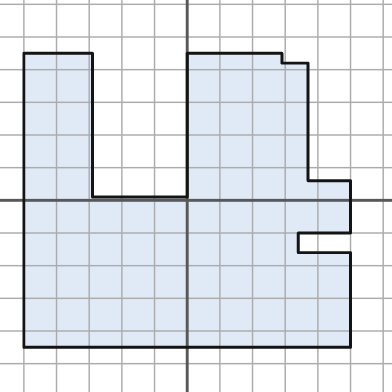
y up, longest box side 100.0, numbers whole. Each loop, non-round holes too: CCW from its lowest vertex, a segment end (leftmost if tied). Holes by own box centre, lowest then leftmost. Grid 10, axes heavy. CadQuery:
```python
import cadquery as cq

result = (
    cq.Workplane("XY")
    .moveTo(-50.0, -45.0)
    .lineTo(50.0, -45.0)
    .lineTo(50.0, -16.0)
    .lineTo(34.0, -16.0)
    .lineTo(34.0, -10.0)
    .lineTo(50.0, -10.0)
    .lineTo(50.0, 6.0)
    .lineTo(37.0, 6.0)
    .lineTo(37.0, 42.0)
    .lineTo(29.0, 42.0)
    .lineTo(29.0, 45.0)
    .lineTo(0.0, 45.0)
    .lineTo(0.0, 1.0)
    .lineTo(-29.0, 1.0)
    .lineTo(-29.0, 45.0)
    .lineTo(-50.0, 45.0)
    .close()
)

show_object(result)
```